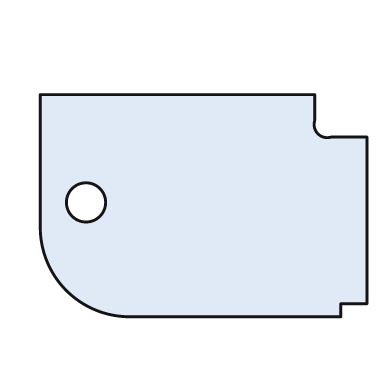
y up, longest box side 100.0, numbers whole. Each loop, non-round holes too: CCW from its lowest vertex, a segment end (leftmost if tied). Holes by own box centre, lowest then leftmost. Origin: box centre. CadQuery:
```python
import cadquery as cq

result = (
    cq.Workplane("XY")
    .moveTo(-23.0, -34.0)
    .lineTo(42.0, -34.0)
    .lineTo(42.0, -30.0)
    .lineTo(50.0, -30.0)
    .lineTo(50.0, 21.0)
    .lineTo(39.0, 21.0)
    .threePointArc((35.0, 22.0), (34.0, 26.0))
    .lineTo(34.0, 34.0)
    .lineTo(-50.0, 34.0)
    .lineTo(-50.0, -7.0)
    .threePointArc((-42.0, -26.0), (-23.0, -34.0))
    .close()
    .moveTo(-36.0, 1.0)
    .circle(6.0)
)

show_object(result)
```